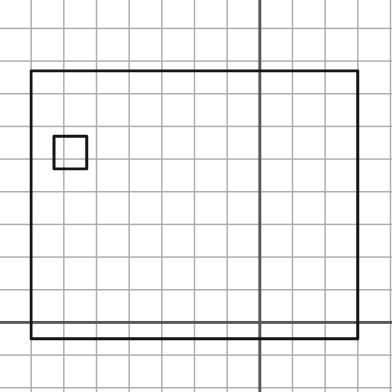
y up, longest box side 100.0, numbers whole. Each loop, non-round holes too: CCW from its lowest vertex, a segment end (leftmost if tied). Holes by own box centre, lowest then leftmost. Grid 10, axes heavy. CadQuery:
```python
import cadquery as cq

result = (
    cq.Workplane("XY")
    .moveTo(-70.0, -5.0)
    .lineTo(30.0, -5.0)
    .lineTo(30.0, 77.0)
    .lineTo(-70.0, 77.0)
    .close()
    .moveTo(-63.0, 47.0)
    .lineTo(-53.0, 47.0)
    .lineTo(-53.0, 57.0)
    .lineTo(-63.0, 57.0)
    .close()
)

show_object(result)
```